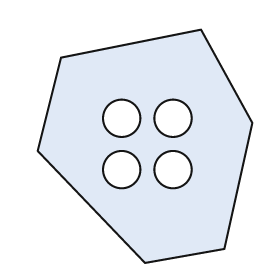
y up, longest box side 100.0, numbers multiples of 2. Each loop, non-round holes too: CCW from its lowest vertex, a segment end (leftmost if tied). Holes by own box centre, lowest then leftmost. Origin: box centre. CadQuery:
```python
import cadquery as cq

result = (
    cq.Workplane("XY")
    .moveTo(0.0, -50.0)
    .lineTo(34.0, -44.0)
    .lineTo(46.0, 10.0)
    .lineTo(24.0, 50.0)
    .lineTo(-36.0, 38.0)
    .lineTo(-46.0, -2.0)
    .close()
    .moveTo(-10.0, -10.0)
    .circle(8.0)
    .moveTo(12.0, -10.0)
    .circle(8.0)
    .moveTo(-10.0, 12.0)
    .circle(8.0)
    .moveTo(12.0, 12.0)
    .circle(8.0)
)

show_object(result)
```